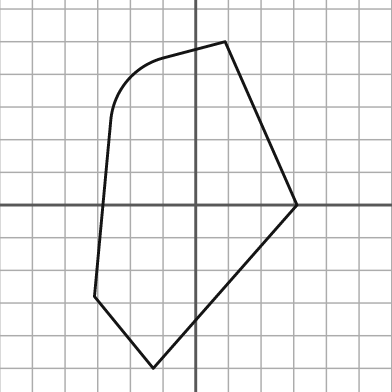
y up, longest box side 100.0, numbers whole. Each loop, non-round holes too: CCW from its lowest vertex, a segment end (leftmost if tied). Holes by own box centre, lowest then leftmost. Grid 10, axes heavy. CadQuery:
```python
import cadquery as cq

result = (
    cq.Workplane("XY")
    .moveTo(-13.0, -50.0)
    .lineTo(31.0, 0.0)
    .lineTo(9.0, 50.0)
    .lineTo(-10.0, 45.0)
    .threePointArc((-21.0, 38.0), (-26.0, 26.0))
    .lineTo(-31.0, -28.0)
    .close()
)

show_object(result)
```